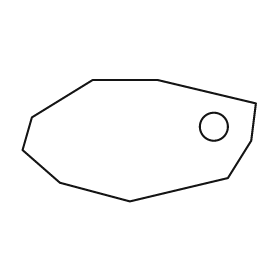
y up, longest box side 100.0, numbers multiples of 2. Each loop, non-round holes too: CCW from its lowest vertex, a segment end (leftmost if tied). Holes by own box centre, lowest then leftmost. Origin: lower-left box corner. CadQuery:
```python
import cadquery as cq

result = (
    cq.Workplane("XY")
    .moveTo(46.0, 0.0)
    .lineTo(88.0, 10.0)
    .lineTo(98.0, 26.0)
    .lineTo(100.0, 42.0)
    .lineTo(58.0, 52.0)
    .lineTo(30.0, 52.0)
    .lineTo(4.0, 36.0)
    .lineTo(0.0, 22.0)
    .lineTo(16.0, 8.0)
    .close()
    .moveTo(82.0, 32.0)
    .circle(6.0)
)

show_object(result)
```